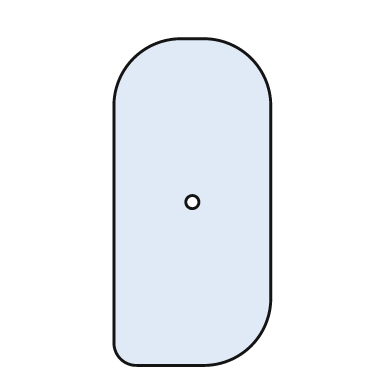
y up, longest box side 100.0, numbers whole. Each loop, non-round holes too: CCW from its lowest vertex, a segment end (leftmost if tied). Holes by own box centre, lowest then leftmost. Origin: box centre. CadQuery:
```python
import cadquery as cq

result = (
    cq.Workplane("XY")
    .moveTo(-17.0, -50.0)
    .lineTo(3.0, -50.0)
    .threePointArc((18.0, -44.0), (24.0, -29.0))
    .lineTo(24.0, 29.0)
    .threePointArc((18.0, 44.0), (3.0, 50.0))
    .lineTo(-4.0, 50.0)
    .threePointArc((-18.0, 44.0), (-24.0, 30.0))
    .lineTo(-24.0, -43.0)
    .threePointArc((-22.0, -48.0), (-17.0, -50.0))
    .close()
    .moveTo(0.0, 0.0)
    .circle(2.0)
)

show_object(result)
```